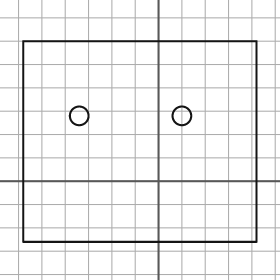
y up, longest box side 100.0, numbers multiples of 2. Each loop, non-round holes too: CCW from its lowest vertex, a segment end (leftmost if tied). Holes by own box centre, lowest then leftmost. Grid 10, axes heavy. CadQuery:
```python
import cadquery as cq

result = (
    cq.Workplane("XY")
    .moveTo(-58.0, -26.0)
    .lineTo(42.0, -26.0)
    .lineTo(42.0, 60.0)
    .lineTo(-58.0, 60.0)
    .close()
    .moveTo(-34.0, 28.0)
    .circle(4.0)
    .moveTo(10.0, 28.0)
    .circle(4.0)
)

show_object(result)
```